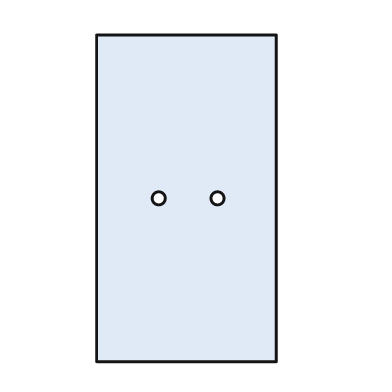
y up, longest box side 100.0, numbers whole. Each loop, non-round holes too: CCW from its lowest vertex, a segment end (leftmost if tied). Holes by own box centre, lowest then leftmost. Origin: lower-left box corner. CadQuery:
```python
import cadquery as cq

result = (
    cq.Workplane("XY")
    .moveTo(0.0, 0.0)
    .lineTo(55.0, 0.0)
    .lineTo(55.0, 100.0)
    .lineTo(0.0, 100.0)
    .close()
    .moveTo(19.0, 50.0)
    .circle(2.0)
    .moveTo(37.0, 50.0)
    .circle(2.0)
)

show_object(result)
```